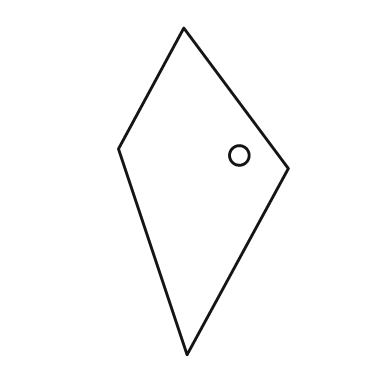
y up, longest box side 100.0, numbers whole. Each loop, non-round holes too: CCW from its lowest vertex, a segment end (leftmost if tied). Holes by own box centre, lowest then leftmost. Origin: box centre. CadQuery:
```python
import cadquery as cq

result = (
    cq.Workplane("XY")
    .moveTo(-5.0, -50.0)
    .lineTo(26.0, 7.0)
    .lineTo(-6.0, 50.0)
    .lineTo(-26.0, 13.0)
    .close()
    .moveTo(11.0, 11.0)
    .circle(3.0)
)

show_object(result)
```